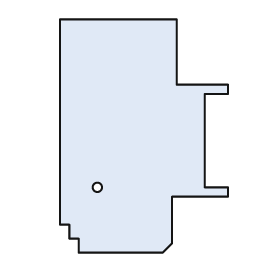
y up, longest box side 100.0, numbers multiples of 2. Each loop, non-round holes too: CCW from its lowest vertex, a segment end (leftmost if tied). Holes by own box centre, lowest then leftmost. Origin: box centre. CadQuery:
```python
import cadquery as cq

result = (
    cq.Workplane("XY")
    .moveTo(-28.0, -50.0)
    .lineTo(8.0, -50.0)
    .lineTo(12.0, -46.0)
    .lineTo(12.0, -26.0)
    .lineTo(36.0, -26.0)
    .lineTo(36.0, -22.0)
    .lineTo(26.0, -22.0)
    .lineTo(26.0, 18.0)
    .lineTo(36.0, 18.0)
    .lineTo(36.0, 22.0)
    .lineTo(14.0, 22.0)
    .lineTo(14.0, 50.0)
    .lineTo(-36.0, 50.0)
    .lineTo(-36.0, -38.0)
    .lineTo(-32.0, -38.0)
    .lineTo(-32.0, -44.0)
    .lineTo(-28.0, -44.0)
    .close()
    .moveTo(-20.0, -22.0)
    .circle(2.0)
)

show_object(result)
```